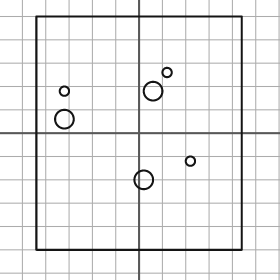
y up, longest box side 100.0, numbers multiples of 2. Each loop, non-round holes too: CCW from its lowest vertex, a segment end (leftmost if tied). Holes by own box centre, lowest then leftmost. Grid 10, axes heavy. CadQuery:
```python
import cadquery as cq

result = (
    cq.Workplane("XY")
    .moveTo(-44.0, -50.0)
    .lineTo(44.0, -50.0)
    .lineTo(44.0, 50.0)
    .lineTo(-44.0, 50.0)
    .close()
    .moveTo(2.0, -20.0)
    .circle(4.0)
    .moveTo(22.0, -12.0)
    .circle(2.0)
    .moveTo(-32.0, 6.0)
    .circle(4.0)
    .moveTo(-32.0, 18.0)
    .circle(2.0)
    .moveTo(6.0, 18.0)
    .circle(4.0)
    .moveTo(12.0, 26.0)
    .circle(2.0)
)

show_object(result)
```